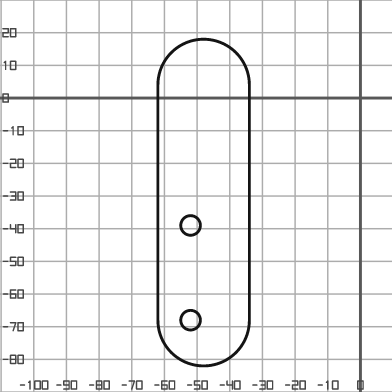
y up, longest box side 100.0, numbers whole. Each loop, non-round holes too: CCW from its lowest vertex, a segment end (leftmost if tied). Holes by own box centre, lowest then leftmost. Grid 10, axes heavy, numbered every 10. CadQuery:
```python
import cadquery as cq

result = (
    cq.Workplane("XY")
    .moveTo(-62.0, -68.0)
    .threePointArc((-48.0, -82.0), (-34.0, -68.0))
    .lineTo(-34.0, 4.0)
    .threePointArc((-48.0, 18.0), (-62.0, 4.0))
    .close()
    .moveTo(-52.0, -68.0)
    .circle(3.0)
    .moveTo(-52.0, -39.0)
    .circle(3.0)
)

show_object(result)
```